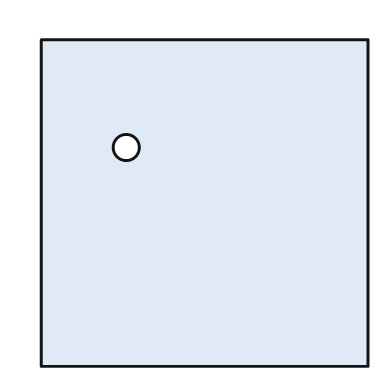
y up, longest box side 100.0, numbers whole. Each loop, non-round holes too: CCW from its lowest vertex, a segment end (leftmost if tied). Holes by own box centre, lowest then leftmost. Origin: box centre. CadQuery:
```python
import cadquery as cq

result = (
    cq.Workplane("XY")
    .moveTo(-50.0, -50.0)
    .lineTo(50.0, -50.0)
    .lineTo(50.0, 50.0)
    .lineTo(-50.0, 50.0)
    .close()
    .moveTo(-24.0, 17.0)
    .circle(4.0)
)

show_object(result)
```